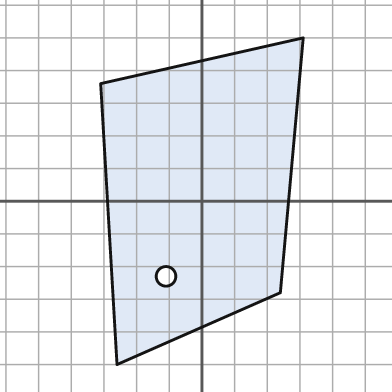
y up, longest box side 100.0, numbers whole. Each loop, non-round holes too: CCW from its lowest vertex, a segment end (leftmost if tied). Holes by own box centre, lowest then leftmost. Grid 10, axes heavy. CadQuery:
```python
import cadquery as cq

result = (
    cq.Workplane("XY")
    .moveTo(-26.0, -50.0)
    .lineTo(24.0, -28.0)
    .lineTo(31.0, 50.0)
    .lineTo(-31.0, 36.0)
    .close()
    .moveTo(-11.0, -23.0)
    .circle(3.0)
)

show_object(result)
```